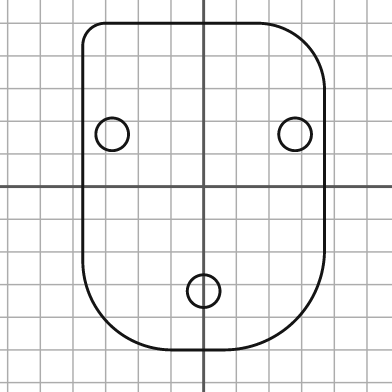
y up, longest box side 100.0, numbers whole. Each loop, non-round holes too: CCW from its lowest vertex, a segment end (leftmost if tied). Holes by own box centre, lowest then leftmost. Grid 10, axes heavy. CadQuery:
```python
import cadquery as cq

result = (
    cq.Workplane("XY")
    .moveTo(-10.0, -50.0)
    .lineTo(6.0, -50.0)
    .threePointArc((28.0, -41.0), (37.0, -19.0))
    .lineTo(37.0, 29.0)
    .threePointArc((31.0, 44.0), (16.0, 50.0))
    .lineTo(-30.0, 50.0)
    .threePointArc((-35.0, 48.0), (-37.0, 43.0))
    .lineTo(-37.0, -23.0)
    .threePointArc((-29.0, -42.0), (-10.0, -50.0))
    .close()
    .moveTo(0.0, -32.0)
    .circle(5.0)
    .moveTo(-28.0, 16.0)
    .circle(5.0)
    .moveTo(28.0, 16.0)
    .circle(5.0)
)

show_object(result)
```